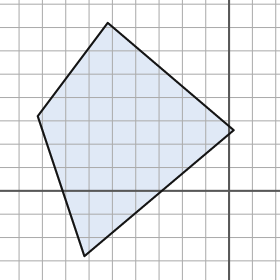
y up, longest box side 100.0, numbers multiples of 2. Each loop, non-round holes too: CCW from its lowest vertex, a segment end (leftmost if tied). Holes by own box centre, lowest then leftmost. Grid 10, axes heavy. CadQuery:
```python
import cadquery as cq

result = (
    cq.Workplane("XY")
    .moveTo(-62.0, -28.0)
    .lineTo(2.0, 26.0)
    .lineTo(-52.0, 72.0)
    .lineTo(-82.0, 32.0)
    .close()
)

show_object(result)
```